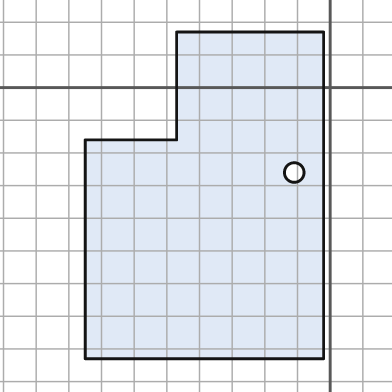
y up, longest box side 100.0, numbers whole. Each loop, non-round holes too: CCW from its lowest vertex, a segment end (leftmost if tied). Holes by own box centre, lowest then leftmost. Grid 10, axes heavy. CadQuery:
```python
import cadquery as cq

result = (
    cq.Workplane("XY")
    .moveTo(-75.0, -83.0)
    .lineTo(-2.0, -83.0)
    .lineTo(-2.0, 17.0)
    .lineTo(-47.0, 17.0)
    .lineTo(-47.0, -16.0)
    .lineTo(-75.0, -16.0)
    .close()
    .moveTo(-11.0, -26.0)
    .circle(3.0)
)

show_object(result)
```